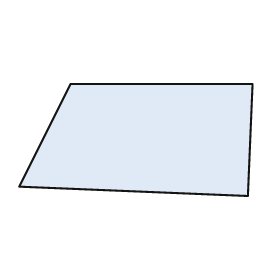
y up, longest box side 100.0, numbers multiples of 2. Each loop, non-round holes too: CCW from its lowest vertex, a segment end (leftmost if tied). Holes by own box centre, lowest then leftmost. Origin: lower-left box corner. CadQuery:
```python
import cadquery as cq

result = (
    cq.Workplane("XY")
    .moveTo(98.0, 0.0)
    .lineTo(100.0, 48.0)
    .lineTo(22.0, 48.0)
    .lineTo(0.0, 4.0)
    .close()
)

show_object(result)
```